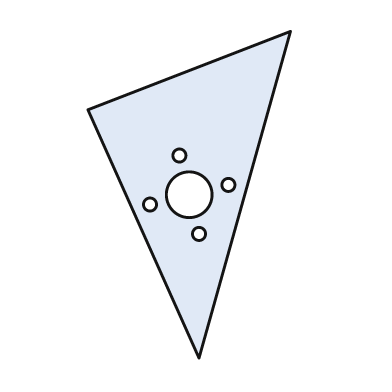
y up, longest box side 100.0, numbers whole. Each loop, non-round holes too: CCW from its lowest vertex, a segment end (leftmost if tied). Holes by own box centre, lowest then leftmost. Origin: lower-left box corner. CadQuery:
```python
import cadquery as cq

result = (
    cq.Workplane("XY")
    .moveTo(34.0, 0.0)
    .lineTo(62.0, 100.0)
    .lineTo(0.0, 76.0)
    .close()
    .moveTo(34.0, 38.0)
    .circle(2.0)
    .moveTo(19.0, 47.0)
    .circle(2.0)
    .moveTo(31.0, 50.0)
    .circle(7.0)
    .moveTo(43.0, 53.0)
    .circle(2.0)
    .moveTo(28.0, 62.0)
    .circle(2.0)
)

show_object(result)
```